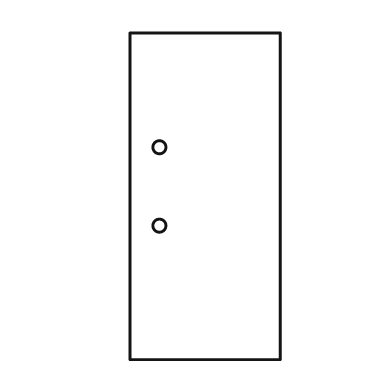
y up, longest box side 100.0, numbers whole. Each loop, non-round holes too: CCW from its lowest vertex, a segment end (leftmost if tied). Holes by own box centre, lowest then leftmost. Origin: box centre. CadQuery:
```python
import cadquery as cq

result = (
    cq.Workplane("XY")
    .moveTo(-23.0, -50.0)
    .lineTo(23.0, -50.0)
    .lineTo(23.0, 50.0)
    .lineTo(-23.0, 50.0)
    .close()
    .moveTo(-14.0, -9.0)
    .circle(2.0)
    .moveTo(-14.0, 15.0)
    .circle(2.0)
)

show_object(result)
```